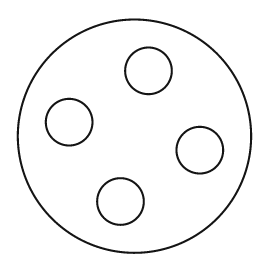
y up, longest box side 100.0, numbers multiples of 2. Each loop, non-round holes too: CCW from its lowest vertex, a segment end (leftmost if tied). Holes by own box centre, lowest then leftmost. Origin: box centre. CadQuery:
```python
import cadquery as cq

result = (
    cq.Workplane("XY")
    .moveTo(0.0, 0.0)
    .circle(50.0)
    .moveTo(-6.0, -28.0)
    .circle(10.0)
    .moveTo(28.0, -6.0)
    .circle(10.0)
    .moveTo(-28.0, 6.0)
    .circle(10.0)
    .moveTo(6.0, 28.0)
    .circle(10.0)
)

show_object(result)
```